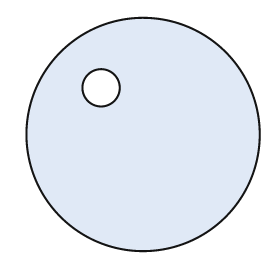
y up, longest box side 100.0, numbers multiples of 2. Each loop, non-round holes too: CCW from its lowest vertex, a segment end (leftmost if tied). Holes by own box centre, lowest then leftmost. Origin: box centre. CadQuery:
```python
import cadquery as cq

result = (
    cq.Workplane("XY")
    .moveTo(0.0, 0.0)
    .circle(50.0)
    .moveTo(-18.0, 20.0)
    .circle(8.0)
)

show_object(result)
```